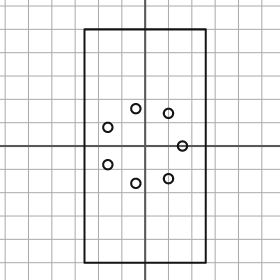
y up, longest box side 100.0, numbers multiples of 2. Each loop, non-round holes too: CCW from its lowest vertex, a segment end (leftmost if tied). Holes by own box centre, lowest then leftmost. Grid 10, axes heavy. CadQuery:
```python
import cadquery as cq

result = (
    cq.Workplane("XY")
    .moveTo(-26.0, -50.0)
    .lineTo(26.0, -50.0)
    .lineTo(26.0, 50.0)
    .lineTo(-26.0, 50.0)
    .close()
    .moveTo(-4.0, -16.0)
    .circle(2.0)
    .moveTo(10.0, -14.0)
    .circle(2.0)
    .moveTo(-16.0, -8.0)
    .circle(2.0)
    .moveTo(16.0, 0.0)
    .circle(2.0)
    .moveTo(-16.0, 8.0)
    .circle(2.0)
    .moveTo(10.0, 14.0)
    .circle(2.0)
    .moveTo(-4.0, 16.0)
    .circle(2.0)
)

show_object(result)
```